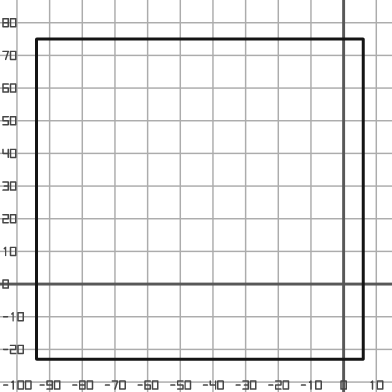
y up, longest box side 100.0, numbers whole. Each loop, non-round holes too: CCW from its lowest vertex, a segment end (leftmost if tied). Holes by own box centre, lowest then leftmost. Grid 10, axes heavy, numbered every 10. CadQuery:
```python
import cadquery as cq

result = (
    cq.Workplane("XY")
    .moveTo(-94.0, -23.0)
    .lineTo(6.0, -23.0)
    .lineTo(6.0, 75.0)
    .lineTo(-94.0, 75.0)
    .close()
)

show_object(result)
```